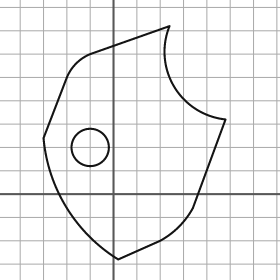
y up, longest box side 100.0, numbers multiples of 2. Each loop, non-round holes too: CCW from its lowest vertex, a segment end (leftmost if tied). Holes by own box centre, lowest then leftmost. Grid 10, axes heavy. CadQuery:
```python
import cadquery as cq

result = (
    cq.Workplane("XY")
    .moveTo(2.0, -28.0)
    .lineTo(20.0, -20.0)
    .threePointArc((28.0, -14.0), (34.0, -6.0))
    .lineTo(48.0, 32.0)
    .threePointArc((26.0, 46.0), (24.0, 72.0))
    .lineTo(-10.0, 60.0)
    .threePointArc((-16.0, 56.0), (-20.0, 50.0))
    .lineTo(-30.0, 24.0)
    .threePointArc((-20.0, -6.0), (2.0, -28.0))
    .close()
    .moveTo(-10.0, 20.0)
    .circle(8.0)
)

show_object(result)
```